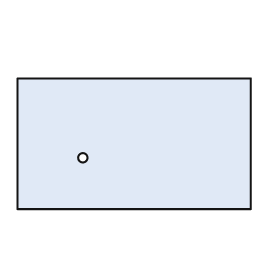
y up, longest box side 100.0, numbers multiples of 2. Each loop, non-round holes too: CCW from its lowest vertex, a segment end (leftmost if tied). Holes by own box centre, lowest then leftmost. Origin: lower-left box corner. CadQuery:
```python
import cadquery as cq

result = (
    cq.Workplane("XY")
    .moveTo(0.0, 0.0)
    .lineTo(100.0, 0.0)
    .lineTo(100.0, 56.0)
    .lineTo(0.0, 56.0)
    .close()
    .moveTo(28.0, 22.0)
    .circle(2.0)
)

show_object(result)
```